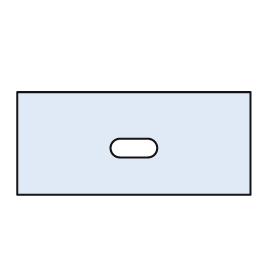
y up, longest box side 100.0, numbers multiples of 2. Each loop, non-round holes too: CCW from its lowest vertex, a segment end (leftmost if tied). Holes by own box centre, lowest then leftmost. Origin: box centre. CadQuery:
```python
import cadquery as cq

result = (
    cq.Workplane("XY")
    .moveTo(-50.0, -22.0)
    .lineTo(50.0, -22.0)
    .lineTo(50.0, 22.0)
    .lineTo(-50.0, 22.0)
    .close()
    .moveTo(-6.0, -6.0)
    .lineTo(6.0, -6.0)
    .threePointArc((10.0, -2.0), (6.0, 2.0))
    .lineTo(-6.0, 2.0)
    .threePointArc((-10.0, -2.0), (-6.0, -6.0))
    .close()
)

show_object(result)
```